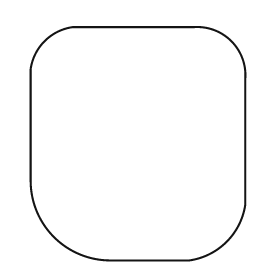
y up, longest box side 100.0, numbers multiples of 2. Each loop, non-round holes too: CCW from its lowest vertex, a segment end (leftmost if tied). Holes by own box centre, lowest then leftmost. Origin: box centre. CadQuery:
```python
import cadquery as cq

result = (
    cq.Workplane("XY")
    .moveTo(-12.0, -50.0)
    .lineTo(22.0, -50.0)
    .threePointArc((38.0, -42.0), (46.0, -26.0))
    .lineTo(46.0, 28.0)
    .threePointArc((40.0, 44.0), (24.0, 50.0))
    .lineTo(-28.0, 50.0)
    .threePointArc((-40.0, 44.0), (-46.0, 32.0))
    .lineTo(-46.0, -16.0)
    .threePointArc((-36.0, -40.0), (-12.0, -50.0))
    .close()
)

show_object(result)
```